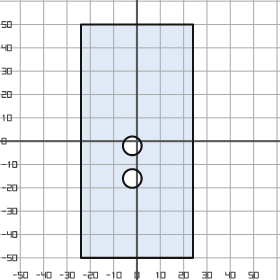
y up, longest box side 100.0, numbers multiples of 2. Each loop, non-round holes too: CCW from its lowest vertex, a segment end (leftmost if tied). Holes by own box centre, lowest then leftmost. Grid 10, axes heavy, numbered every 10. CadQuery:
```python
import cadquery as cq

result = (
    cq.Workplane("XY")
    .moveTo(-24.0, -50.0)
    .lineTo(24.0, -50.0)
    .lineTo(24.0, 50.0)
    .lineTo(-24.0, 50.0)
    .close()
    .moveTo(-2.0, -16.0)
    .circle(4.0)
    .moveTo(-2.0, -2.0)
    .circle(4.0)
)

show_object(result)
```